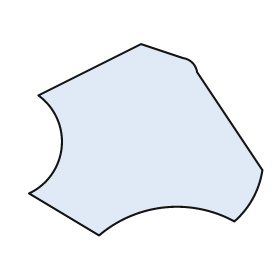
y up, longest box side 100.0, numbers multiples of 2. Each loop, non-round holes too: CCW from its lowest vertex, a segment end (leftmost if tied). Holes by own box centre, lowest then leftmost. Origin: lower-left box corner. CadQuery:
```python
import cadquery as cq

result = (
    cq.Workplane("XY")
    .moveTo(30.0, 0.0)
    .threePointArc((58.0, 12.0), (88.0, 6.0))
    .threePointArc((96.0, 16.0), (100.0, 28.0))
    .lineTo(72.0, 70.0)
    .threePointArc((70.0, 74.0), (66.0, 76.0))
    .lineTo(48.0, 82.0)
    .lineTo(4.0, 60.0)
    .threePointArc((14.0, 38.0), (0.0, 18.0))
    .close()
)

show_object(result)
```